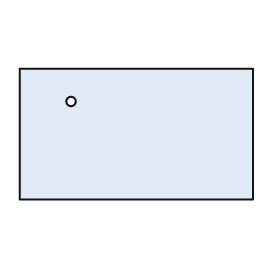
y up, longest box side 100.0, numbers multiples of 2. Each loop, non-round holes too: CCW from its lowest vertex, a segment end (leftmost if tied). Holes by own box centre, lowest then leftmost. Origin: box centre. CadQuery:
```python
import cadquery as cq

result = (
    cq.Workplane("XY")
    .moveTo(-50.0, -28.0)
    .lineTo(50.0, -28.0)
    .lineTo(50.0, 28.0)
    .lineTo(-50.0, 28.0)
    .close()
    .moveTo(-28.0, 14.0)
    .circle(2.0)
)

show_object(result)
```